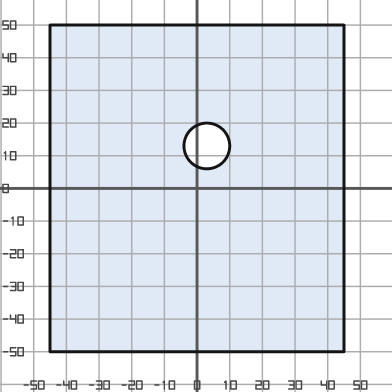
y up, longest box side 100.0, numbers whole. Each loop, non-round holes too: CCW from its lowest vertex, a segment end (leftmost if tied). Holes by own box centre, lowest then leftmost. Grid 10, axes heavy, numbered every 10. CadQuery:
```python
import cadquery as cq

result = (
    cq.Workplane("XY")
    .moveTo(-45.0, -50.0)
    .lineTo(45.0, -50.0)
    .lineTo(45.0, 50.0)
    .lineTo(-45.0, 50.0)
    .close()
    .moveTo(3.0, 13.0)
    .circle(7.0)
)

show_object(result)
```